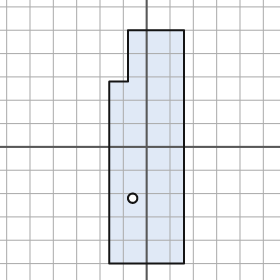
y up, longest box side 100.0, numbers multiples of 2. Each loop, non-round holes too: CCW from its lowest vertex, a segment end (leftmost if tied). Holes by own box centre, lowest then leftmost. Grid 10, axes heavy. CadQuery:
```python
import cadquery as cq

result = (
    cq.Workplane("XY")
    .moveTo(-16.0, -50.0)
    .lineTo(16.0, -50.0)
    .lineTo(16.0, 50.0)
    .lineTo(-8.0, 50.0)
    .lineTo(-8.0, 28.0)
    .lineTo(-16.0, 28.0)
    .close()
    .moveTo(-6.0, -22.0)
    .circle(2.0)
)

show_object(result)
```